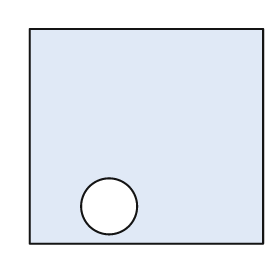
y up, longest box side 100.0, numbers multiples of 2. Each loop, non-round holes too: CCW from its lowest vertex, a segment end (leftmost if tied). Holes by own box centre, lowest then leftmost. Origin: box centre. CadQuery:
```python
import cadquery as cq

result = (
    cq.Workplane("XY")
    .moveTo(-50.0, -46.0)
    .lineTo(50.0, -46.0)
    .lineTo(50.0, 46.0)
    .lineTo(-50.0, 46.0)
    .close()
    .moveTo(-16.0, -30.0)
    .circle(12.0)
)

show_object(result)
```